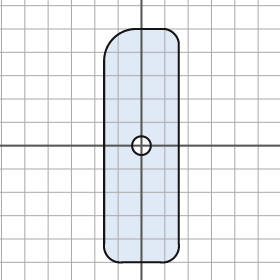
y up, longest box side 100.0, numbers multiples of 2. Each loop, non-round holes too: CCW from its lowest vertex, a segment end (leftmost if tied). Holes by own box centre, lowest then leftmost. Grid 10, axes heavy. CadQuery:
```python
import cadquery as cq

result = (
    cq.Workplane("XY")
    .moveTo(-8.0, -50.0)
    .lineTo(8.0, -50.0)
    .threePointArc((14.0, -48.0), (16.0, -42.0))
    .lineTo(16.0, 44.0)
    .threePointArc((14.0, 48.0), (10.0, 50.0))
    .lineTo(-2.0, 50.0)
    .threePointArc((-12.0, 46.0), (-16.0, 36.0))
    .lineTo(-16.0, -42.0)
    .threePointArc((-14.0, -48.0), (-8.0, -50.0))
    .close()
    .moveTo(0.0, 0.0)
    .circle(4.0)
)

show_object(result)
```